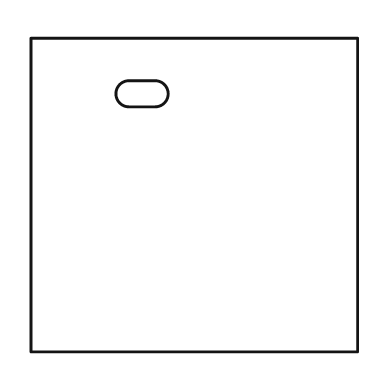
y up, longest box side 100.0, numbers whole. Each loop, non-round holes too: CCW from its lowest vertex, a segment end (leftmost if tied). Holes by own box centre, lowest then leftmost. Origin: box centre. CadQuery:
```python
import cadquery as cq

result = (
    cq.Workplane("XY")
    .moveTo(-50.0, -48.0)
    .lineTo(50.0, -48.0)
    .lineTo(50.0, 48.0)
    .lineTo(-50.0, 48.0)
    .close()
    .moveTo(-20.0, 27.0)
    .lineTo(-12.0, 27.0)
    .threePointArc((-8.0, 31.0), (-12.0, 35.0))
    .lineTo(-20.0, 35.0)
    .threePointArc((-24.0, 31.0), (-20.0, 27.0))
    .close()
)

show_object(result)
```